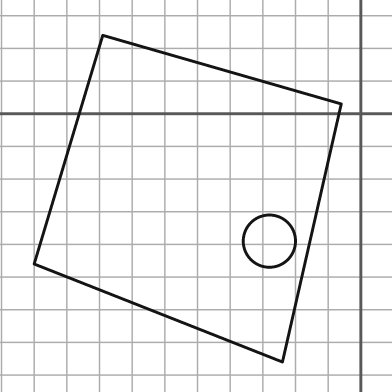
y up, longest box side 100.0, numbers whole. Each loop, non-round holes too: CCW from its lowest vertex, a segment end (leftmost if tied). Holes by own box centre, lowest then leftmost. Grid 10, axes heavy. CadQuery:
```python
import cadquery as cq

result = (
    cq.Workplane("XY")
    .moveTo(-24.0, -76.0)
    .lineTo(-6.0, 3.0)
    .lineTo(-79.0, 24.0)
    .lineTo(-100.0, -46.0)
    .close()
    .moveTo(-28.0, -39.0)
    .circle(8.0)
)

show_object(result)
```